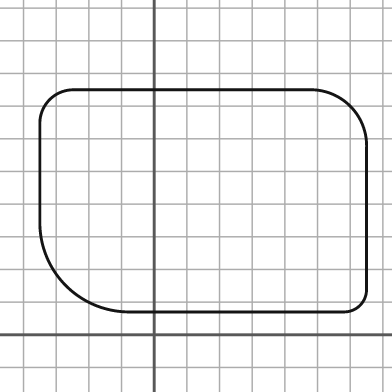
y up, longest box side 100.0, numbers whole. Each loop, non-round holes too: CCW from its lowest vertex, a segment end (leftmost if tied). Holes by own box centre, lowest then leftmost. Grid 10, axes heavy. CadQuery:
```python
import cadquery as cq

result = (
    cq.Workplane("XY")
    .moveTo(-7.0, 7.0)
    .lineTo(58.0, 7.0)
    .threePointArc((63.0, 9.0), (65.0, 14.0))
    .lineTo(65.0, 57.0)
    .threePointArc((60.0, 70.0), (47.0, 75.0))
    .lineTo(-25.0, 75.0)
    .threePointArc((-32.0, 72.0), (-35.0, 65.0))
    .lineTo(-35.0, 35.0)
    .threePointArc((-27.0, 15.0), (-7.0, 7.0))
    .close()
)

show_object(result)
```